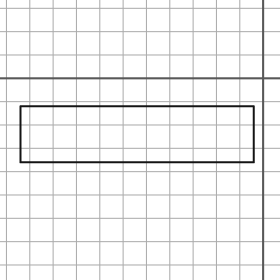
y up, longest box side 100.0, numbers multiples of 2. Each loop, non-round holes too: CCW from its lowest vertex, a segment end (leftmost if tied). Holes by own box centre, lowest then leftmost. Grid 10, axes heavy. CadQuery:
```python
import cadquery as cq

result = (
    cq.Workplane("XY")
    .moveTo(-104.0, -36.0)
    .lineTo(-4.0, -36.0)
    .lineTo(-4.0, -12.0)
    .lineTo(-104.0, -12.0)
    .close()
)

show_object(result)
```